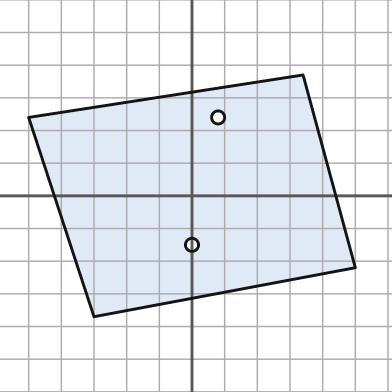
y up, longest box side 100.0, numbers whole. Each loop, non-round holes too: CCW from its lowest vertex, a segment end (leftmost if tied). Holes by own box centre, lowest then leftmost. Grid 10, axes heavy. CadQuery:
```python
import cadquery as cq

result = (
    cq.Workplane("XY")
    .moveTo(-30.0, -37.0)
    .lineTo(50.0, -22.0)
    .lineTo(34.0, 37.0)
    .lineTo(-50.0, 24.0)
    .close()
    .moveTo(0.0, -15.0)
    .circle(2.0)
    .moveTo(8.0, 24.0)
    .circle(2.0)
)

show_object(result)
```